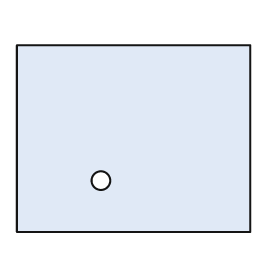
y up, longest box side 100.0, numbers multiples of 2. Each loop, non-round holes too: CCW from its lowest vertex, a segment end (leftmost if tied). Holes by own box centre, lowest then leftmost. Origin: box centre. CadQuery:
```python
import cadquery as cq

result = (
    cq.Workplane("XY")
    .moveTo(-50.0, -40.0)
    .lineTo(50.0, -40.0)
    .lineTo(50.0, 40.0)
    .lineTo(-50.0, 40.0)
    .close()
    .moveTo(-14.0, -18.0)
    .circle(4.0)
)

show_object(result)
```